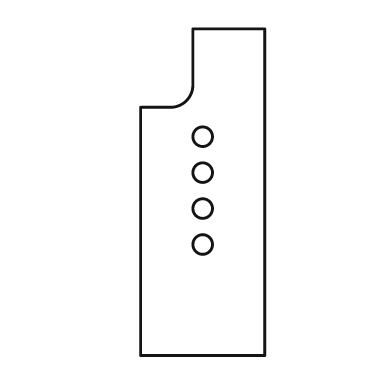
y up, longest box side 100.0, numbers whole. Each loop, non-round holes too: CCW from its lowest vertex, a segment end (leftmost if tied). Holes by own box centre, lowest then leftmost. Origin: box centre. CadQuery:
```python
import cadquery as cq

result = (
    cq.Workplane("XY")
    .moveTo(-19.0, -50.0)
    .lineTo(19.0, -50.0)
    .lineTo(19.0, 50.0)
    .lineTo(-3.0, 50.0)
    .lineTo(-3.0, 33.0)
    .threePointArc((-5.0, 28.0), (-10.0, 26.0))
    .lineTo(-19.0, 26.0)
    .close()
    .moveTo(0.0, -16.0)
    .circle(3.0)
    .moveTo(0.0, -5.0)
    .circle(3.0)
    .moveTo(0.0, 6.0)
    .circle(3.0)
    .moveTo(0.0, 17.0)
    .circle(3.0)
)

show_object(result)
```